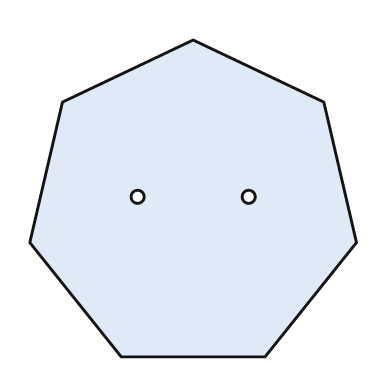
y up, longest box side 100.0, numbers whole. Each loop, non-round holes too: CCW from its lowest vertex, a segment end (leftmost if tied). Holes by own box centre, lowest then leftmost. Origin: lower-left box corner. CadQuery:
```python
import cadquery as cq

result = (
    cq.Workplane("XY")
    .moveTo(28.0, 0.0)
    .lineTo(72.0, 0.0)
    .lineTo(100.0, 35.0)
    .lineTo(90.0, 78.0)
    .lineTo(50.0, 97.0)
    .lineTo(10.0, 78.0)
    .lineTo(0.0, 35.0)
    .close()
    .moveTo(33.0, 49.0)
    .circle(2.0)
    .moveTo(67.0, 49.0)
    .circle(2.0)
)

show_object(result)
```